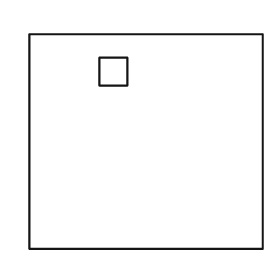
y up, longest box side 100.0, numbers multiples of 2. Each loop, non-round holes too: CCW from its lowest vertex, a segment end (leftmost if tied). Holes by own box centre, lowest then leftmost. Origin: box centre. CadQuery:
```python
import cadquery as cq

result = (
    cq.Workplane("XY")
    .moveTo(-50.0, -46.0)
    .lineTo(50.0, -46.0)
    .lineTo(50.0, 46.0)
    .lineTo(-50.0, 46.0)
    .close()
    .moveTo(-20.0, 24.0)
    .lineTo(-8.0, 24.0)
    .lineTo(-8.0, 36.0)
    .lineTo(-20.0, 36.0)
    .close()
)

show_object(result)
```